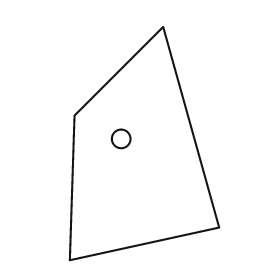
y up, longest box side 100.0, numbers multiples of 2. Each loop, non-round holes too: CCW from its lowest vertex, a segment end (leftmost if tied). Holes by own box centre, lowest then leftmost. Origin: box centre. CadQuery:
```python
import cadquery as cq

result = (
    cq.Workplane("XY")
    .moveTo(-32.0, -50.0)
    .lineTo(32.0, -36.0)
    .lineTo(8.0, 50.0)
    .lineTo(-30.0, 12.0)
    .close()
    .moveTo(-10.0, 2.0)
    .circle(4.0)
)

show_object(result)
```